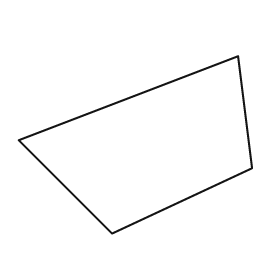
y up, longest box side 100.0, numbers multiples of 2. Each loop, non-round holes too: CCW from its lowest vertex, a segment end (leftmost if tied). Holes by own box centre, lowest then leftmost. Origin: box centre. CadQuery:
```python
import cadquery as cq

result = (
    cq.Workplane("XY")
    .moveTo(-10.0, -38.0)
    .lineTo(50.0, -10.0)
    .lineTo(44.0, 38.0)
    .lineTo(-50.0, 2.0)
    .close()
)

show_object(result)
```